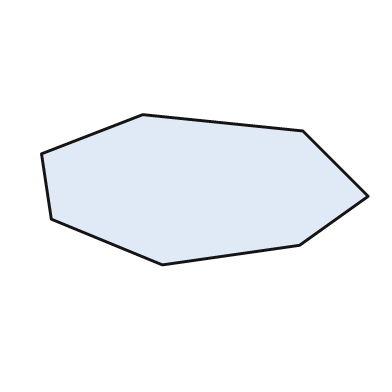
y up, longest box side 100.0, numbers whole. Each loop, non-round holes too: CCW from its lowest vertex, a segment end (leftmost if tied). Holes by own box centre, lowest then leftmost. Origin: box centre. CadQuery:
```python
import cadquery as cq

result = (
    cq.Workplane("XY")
    .moveTo(-13.0, -23.0)
    .lineTo(29.0, -17.0)
    .lineTo(50.0, -2.0)
    .lineTo(30.0, 18.0)
    .lineTo(-19.0, 23.0)
    .lineTo(-50.0, 11.0)
    .lineTo(-47.0, -9.0)
    .close()
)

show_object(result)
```